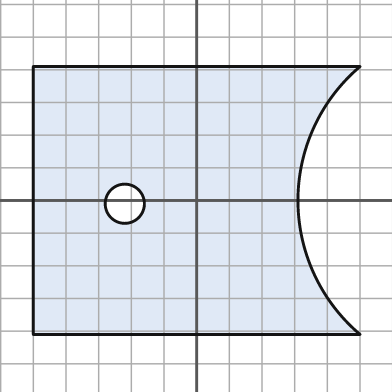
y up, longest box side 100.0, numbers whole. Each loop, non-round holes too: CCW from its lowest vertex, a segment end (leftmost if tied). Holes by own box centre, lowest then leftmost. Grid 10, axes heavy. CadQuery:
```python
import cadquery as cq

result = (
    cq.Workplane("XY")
    .moveTo(-50.0, -41.0)
    .lineTo(50.0, -41.0)
    .threePointArc((31.0, 0.0), (50.0, 41.0))
    .lineTo(-50.0, 41.0)
    .close()
    .moveTo(-22.0, -1.0)
    .circle(6.0)
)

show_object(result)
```